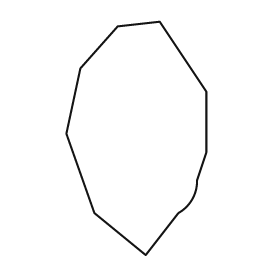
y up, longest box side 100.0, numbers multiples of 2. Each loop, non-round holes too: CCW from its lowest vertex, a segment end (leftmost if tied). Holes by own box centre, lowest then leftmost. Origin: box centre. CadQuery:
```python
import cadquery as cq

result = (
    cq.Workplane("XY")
    .moveTo(4.0, -50.0)
    .lineTo(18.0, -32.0)
    .threePointArc((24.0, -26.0), (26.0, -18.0))
    .lineTo(30.0, -6.0)
    .lineTo(30.0, 20.0)
    .lineTo(10.0, 50.0)
    .lineTo(-8.0, 48.0)
    .lineTo(-24.0, 30.0)
    .lineTo(-30.0, 2.0)
    .lineTo(-18.0, -32.0)
    .close()
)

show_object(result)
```